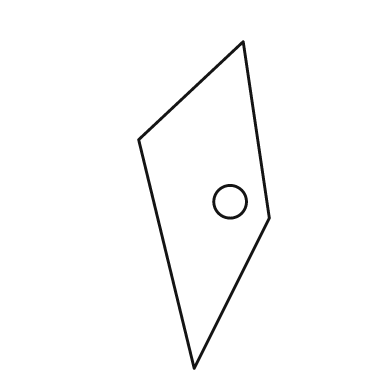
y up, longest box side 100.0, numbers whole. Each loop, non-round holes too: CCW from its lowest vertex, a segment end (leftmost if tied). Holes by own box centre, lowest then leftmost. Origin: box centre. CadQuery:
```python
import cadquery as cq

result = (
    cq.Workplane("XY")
    .moveTo(-3.0, -50.0)
    .lineTo(20.0, -4.0)
    .lineTo(12.0, 50.0)
    .lineTo(-20.0, 20.0)
    .close()
    .moveTo(8.0, 1.0)
    .circle(5.0)
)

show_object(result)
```